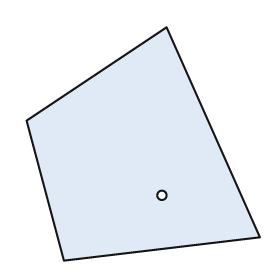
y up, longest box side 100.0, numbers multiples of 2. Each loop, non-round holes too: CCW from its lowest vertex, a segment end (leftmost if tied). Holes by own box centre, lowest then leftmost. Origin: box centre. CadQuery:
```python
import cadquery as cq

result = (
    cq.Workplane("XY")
    .moveTo(-34.0, -50.0)
    .lineTo(50.0, -40.0)
    .lineTo(10.0, 50.0)
    .lineTo(-50.0, 10.0)
    .close()
    .moveTo(8.0, -22.0)
    .circle(2.0)
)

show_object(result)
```